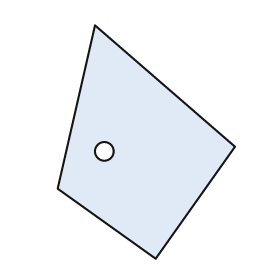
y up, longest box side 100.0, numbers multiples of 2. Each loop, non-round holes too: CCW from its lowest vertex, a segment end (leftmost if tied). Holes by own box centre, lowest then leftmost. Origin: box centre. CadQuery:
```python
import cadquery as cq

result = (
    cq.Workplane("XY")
    .moveTo(4.0, -50.0)
    .lineTo(38.0, -2.0)
    .lineTo(-22.0, 50.0)
    .lineTo(-38.0, -20.0)
    .close()
    .moveTo(-18.0, -4.0)
    .circle(4.0)
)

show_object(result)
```